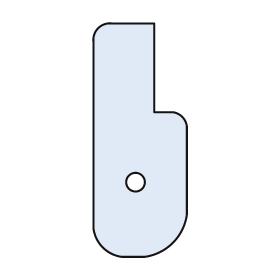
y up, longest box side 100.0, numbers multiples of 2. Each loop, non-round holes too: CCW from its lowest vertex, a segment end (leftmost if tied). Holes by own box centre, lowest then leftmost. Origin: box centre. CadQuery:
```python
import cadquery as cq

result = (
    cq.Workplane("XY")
    .moveTo(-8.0, -50.0)
    .lineTo(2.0, -50.0)
    .threePointArc((14.0, -44.0), (20.0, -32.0))
    .lineTo(20.0, 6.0)
    .threePointArc((18.0, 10.0), (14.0, 12.0))
    .lineTo(6.0, 12.0)
    .lineTo(6.0, 50.0)
    .lineTo(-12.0, 50.0)
    .threePointArc((-18.0, 48.0), (-20.0, 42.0))
    .lineTo(-20.0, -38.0)
    .threePointArc((-16.0, -46.0), (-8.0, -50.0))
    .close()
    .moveTo(-2.0, -18.0)
    .circle(4.0)
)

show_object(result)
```